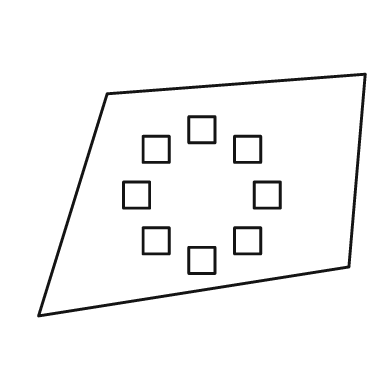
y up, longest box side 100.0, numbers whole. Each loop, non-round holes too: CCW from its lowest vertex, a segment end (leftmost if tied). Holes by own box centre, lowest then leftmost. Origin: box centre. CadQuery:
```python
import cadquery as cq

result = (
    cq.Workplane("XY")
    .moveTo(-50.0, -37.0)
    .lineTo(45.0, -22.0)
    .lineTo(50.0, 37.0)
    .lineTo(-29.0, 31.0)
    .close()
    .moveTo(-4.0, -24.0)
    .lineTo(4.0, -24.0)
    .lineTo(4.0, -16.0)
    .lineTo(-4.0, -16.0)
    .close()
    .moveTo(-18.0, -18.0)
    .lineTo(-10.0, -18.0)
    .lineTo(-10.0, -10.0)
    .lineTo(-18.0, -10.0)
    .close()
    .moveTo(10.0, -18.0)
    .lineTo(18.0, -18.0)
    .lineTo(18.0, -10.0)
    .lineTo(10.0, -10.0)
    .close()
    .moveTo(-24.0, -4.0)
    .lineTo(-16.0, -4.0)
    .lineTo(-16.0, 4.0)
    .lineTo(-24.0, 4.0)
    .close()
    .moveTo(16.0, -4.0)
    .lineTo(24.0, -4.0)
    .lineTo(24.0, 4.0)
    .lineTo(16.0, 4.0)
    .close()
    .moveTo(-18.0, 10.0)
    .lineTo(-10.0, 10.0)
    .lineTo(-10.0, 18.0)
    .lineTo(-18.0, 18.0)
    .close()
    .moveTo(10.0, 10.0)
    .lineTo(18.0, 10.0)
    .lineTo(18.0, 18.0)
    .lineTo(10.0, 18.0)
    .close()
    .moveTo(-4.0, 16.0)
    .lineTo(4.0, 16.0)
    .lineTo(4.0, 24.0)
    .lineTo(-4.0, 24.0)
    .close()
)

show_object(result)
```